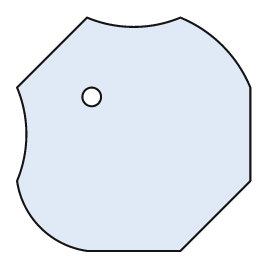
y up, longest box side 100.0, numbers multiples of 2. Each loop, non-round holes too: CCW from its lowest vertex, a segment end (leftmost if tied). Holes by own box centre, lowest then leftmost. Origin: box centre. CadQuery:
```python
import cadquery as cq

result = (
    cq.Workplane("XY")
    .moveTo(-20.0, -50.0)
    .lineTo(20.0, -50.0)
    .lineTo(50.0, -20.0)
    .lineTo(50.0, 20.0)
    .threePointArc((38.0, 38.0), (20.0, 50.0))
    .threePointArc((0.0, 46.0), (-20.0, 50.0))
    .lineTo(-50.0, 20.0)
    .threePointArc((-46.0, 0.0), (-50.0, -20.0))
    .threePointArc((-40.0, -40.0), (-20.0, -50.0))
    .close()
    .moveTo(-18.0, 16.0)
    .circle(4.0)
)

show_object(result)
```